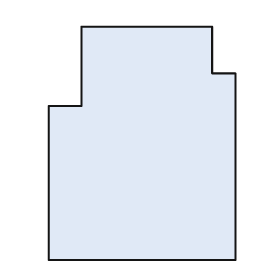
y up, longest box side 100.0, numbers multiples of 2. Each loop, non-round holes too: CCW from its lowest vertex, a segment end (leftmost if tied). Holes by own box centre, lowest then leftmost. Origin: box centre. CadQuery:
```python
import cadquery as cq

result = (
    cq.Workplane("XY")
    .moveTo(-40.0, -50.0)
    .lineTo(40.0, -50.0)
    .lineTo(40.0, 30.0)
    .lineTo(30.0, 30.0)
    .lineTo(30.0, 50.0)
    .lineTo(-26.0, 50.0)
    .lineTo(-26.0, 16.0)
    .lineTo(-40.0, 16.0)
    .close()
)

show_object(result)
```